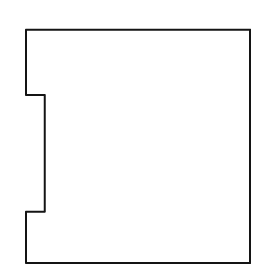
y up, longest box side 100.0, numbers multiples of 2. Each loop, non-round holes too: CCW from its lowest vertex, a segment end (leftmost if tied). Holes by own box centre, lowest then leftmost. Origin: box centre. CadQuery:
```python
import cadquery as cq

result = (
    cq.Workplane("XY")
    .moveTo(-48.0, -50.0)
    .lineTo(48.0, -50.0)
    .lineTo(48.0, 50.0)
    .lineTo(-48.0, 50.0)
    .lineTo(-48.0, 22.0)
    .lineTo(-40.0, 22.0)
    .lineTo(-40.0, -28.0)
    .lineTo(-48.0, -28.0)
    .close()
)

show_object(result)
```